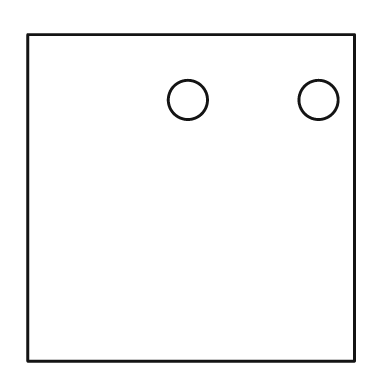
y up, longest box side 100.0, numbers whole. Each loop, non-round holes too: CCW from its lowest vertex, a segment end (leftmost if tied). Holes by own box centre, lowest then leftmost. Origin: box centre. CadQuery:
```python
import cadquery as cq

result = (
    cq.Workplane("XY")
    .moveTo(-50.0, -50.0)
    .lineTo(50.0, -50.0)
    .lineTo(50.0, 50.0)
    .lineTo(-50.0, 50.0)
    .close()
    .moveTo(-1.0, 30.0)
    .circle(6.0)
    .moveTo(39.0, 30.0)
    .circle(6.0)
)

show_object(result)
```